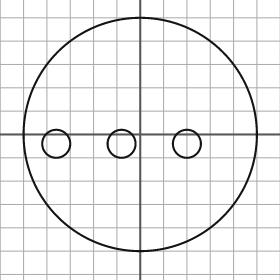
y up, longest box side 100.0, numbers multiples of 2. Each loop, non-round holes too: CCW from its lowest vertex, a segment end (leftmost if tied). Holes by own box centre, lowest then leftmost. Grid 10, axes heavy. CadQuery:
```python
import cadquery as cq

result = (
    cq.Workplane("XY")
    .moveTo(0.0, 0.0)
    .circle(50.0)
    .moveTo(-36.0, -4.0)
    .circle(6.0)
    .moveTo(-8.0, -4.0)
    .circle(6.0)
    .moveTo(20.0, -4.0)
    .circle(6.0)
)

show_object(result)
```